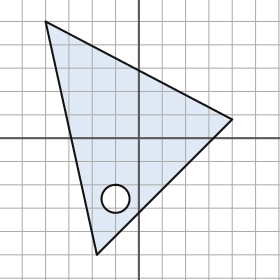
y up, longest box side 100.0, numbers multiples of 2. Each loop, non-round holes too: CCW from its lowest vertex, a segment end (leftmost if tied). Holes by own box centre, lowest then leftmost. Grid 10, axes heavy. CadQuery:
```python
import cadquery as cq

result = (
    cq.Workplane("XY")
    .moveTo(-18.0, -50.0)
    .lineTo(40.0, 8.0)
    .lineTo(-40.0, 50.0)
    .close()
    .moveTo(-10.0, -26.0)
    .circle(6.0)
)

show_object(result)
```